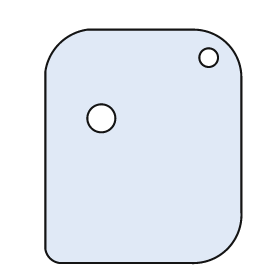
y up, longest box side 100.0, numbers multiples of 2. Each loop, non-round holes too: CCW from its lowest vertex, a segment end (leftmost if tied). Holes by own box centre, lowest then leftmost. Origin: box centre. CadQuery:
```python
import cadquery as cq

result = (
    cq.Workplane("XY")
    .moveTo(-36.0, -50.0)
    .lineTo(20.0, -50.0)
    .threePointArc((36.0, -44.0), (42.0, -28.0))
    .lineTo(42.0, 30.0)
    .threePointArc((36.0, 44.0), (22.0, 50.0))
    .lineTo(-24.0, 50.0)
    .threePointArc((-36.0, 44.0), (-42.0, 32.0))
    .lineTo(-42.0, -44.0)
    .threePointArc((-40.0, -48.0), (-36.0, -50.0))
    .close()
    .moveTo(-18.0, 12.0)
    .circle(6.0)
    .moveTo(28.0, 38.0)
    .circle(4.0)
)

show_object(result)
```